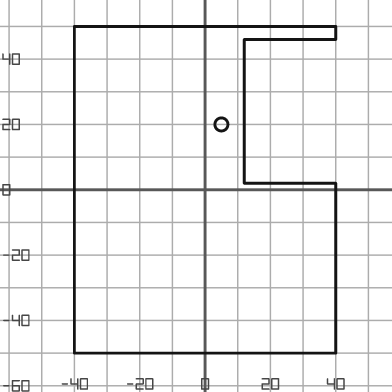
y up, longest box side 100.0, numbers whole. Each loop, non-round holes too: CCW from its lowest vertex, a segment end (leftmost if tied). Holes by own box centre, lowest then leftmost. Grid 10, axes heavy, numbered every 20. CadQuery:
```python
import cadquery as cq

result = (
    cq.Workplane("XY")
    .moveTo(-40.0, -50.0)
    .lineTo(40.0, -50.0)
    .lineTo(40.0, 2.0)
    .lineTo(12.0, 2.0)
    .lineTo(12.0, 46.0)
    .lineTo(40.0, 46.0)
    .lineTo(40.0, 50.0)
    .lineTo(-40.0, 50.0)
    .close()
    .moveTo(5.0, 20.0)
    .circle(2.0)
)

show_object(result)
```